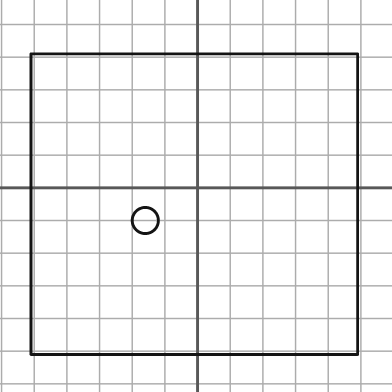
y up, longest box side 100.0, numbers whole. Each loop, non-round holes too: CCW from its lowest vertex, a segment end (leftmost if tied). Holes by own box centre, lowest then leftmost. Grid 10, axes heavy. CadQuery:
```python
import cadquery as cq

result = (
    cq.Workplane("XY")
    .moveTo(-51.0, -51.0)
    .lineTo(49.0, -51.0)
    .lineTo(49.0, 41.0)
    .lineTo(-51.0, 41.0)
    .close()
    .moveTo(-16.0, -10.0)
    .circle(4.0)
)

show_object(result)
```